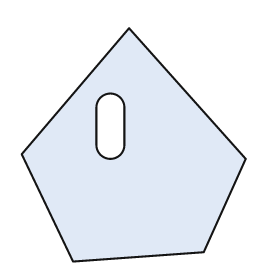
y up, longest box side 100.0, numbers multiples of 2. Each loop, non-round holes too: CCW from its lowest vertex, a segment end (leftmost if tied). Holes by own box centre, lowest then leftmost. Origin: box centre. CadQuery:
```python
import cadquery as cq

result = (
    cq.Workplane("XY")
    .moveTo(-26.0, -50.0)
    .lineTo(30.0, -46.0)
    .lineTo(48.0, -6.0)
    .lineTo(-2.0, 50.0)
    .lineTo(-48.0, -4.0)
    .close()
    .moveTo(-16.0, 0.0)
    .threePointArc((-10.0, -6.0), (-4.0, 0.0))
    .lineTo(-4.0, 16.0)
    .threePointArc((-10.0, 22.0), (-16.0, 16.0))
    .close()
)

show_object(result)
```